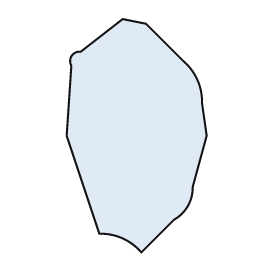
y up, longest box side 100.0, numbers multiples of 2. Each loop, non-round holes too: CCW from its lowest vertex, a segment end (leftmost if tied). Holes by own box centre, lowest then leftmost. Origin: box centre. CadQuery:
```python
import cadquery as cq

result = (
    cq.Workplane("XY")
    .moveTo(2.0, -50.0)
    .lineTo(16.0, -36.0)
    .threePointArc((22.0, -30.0), (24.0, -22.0))
    .lineTo(30.0, 0.0)
    .lineTo(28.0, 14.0)
    .threePointArc((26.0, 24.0), (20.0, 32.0))
    .lineTo(4.0, 48.0)
    .lineTo(-6.0, 50.0)
    .lineTo(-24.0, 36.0)
    .threePointArc((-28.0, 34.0), (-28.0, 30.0))
    .lineTo(-30.0, 0.0)
    .lineTo(-16.0, -42.0)
    .threePointArc((-6.0, -44.0), (2.0, -50.0))
    .close()
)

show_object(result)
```